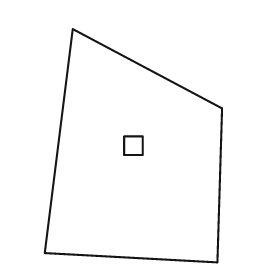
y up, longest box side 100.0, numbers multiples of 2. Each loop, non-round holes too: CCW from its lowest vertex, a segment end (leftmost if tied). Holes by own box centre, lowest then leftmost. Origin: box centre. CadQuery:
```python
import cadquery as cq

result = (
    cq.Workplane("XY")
    .moveTo(36.0, -50.0)
    .lineTo(38.0, 16.0)
    .lineTo(-26.0, 50.0)
    .lineTo(-38.0, -46.0)
    .close()
    .moveTo(-4.0, -4.0)
    .lineTo(4.0, -4.0)
    .lineTo(4.0, 4.0)
    .lineTo(-4.0, 4.0)
    .close()
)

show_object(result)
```